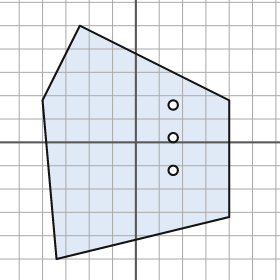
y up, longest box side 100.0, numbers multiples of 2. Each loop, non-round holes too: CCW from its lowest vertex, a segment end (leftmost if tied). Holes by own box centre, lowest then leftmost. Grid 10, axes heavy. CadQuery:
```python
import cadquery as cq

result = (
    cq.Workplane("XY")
    .moveTo(-34.0, -50.0)
    .lineTo(40.0, -32.0)
    .lineTo(40.0, 18.0)
    .lineTo(-24.0, 50.0)
    .lineTo(-40.0, 18.0)
    .close()
    .moveTo(16.0, -12.0)
    .circle(2.0)
    .moveTo(16.0, 2.0)
    .circle(2.0)
    .moveTo(16.0, 16.0)
    .circle(2.0)
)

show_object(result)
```